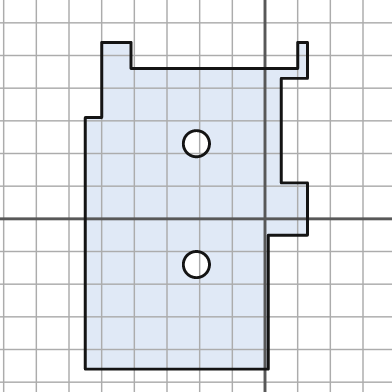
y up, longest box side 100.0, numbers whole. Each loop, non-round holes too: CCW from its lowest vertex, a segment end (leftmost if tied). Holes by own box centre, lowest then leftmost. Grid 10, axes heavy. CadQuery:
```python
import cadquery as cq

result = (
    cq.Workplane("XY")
    .moveTo(-55.0, -46.0)
    .lineTo(1.0, -46.0)
    .lineTo(1.0, -5.0)
    .lineTo(13.0, -5.0)
    .lineTo(13.0, 11.0)
    .lineTo(5.0, 11.0)
    .lineTo(5.0, 43.0)
    .lineTo(13.0, 43.0)
    .lineTo(13.0, 54.0)
    .lineTo(10.0, 54.0)
    .lineTo(10.0, 46.0)
    .lineTo(-41.0, 46.0)
    .lineTo(-41.0, 54.0)
    .lineTo(-50.0, 54.0)
    .lineTo(-50.0, 31.0)
    .lineTo(-55.0, 31.0)
    .close()
    .moveTo(-21.0, -14.0)
    .circle(4.0)
    .moveTo(-21.0, 23.0)
    .circle(4.0)
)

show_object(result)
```